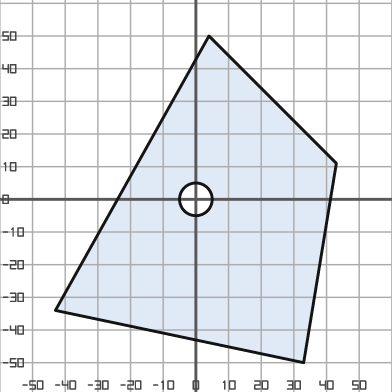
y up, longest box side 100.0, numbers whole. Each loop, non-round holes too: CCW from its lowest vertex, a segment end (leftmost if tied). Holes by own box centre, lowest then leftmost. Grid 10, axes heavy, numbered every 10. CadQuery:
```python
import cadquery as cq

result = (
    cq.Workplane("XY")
    .moveTo(33.0, -50.0)
    .lineTo(43.0, 11.0)
    .lineTo(4.0, 50.0)
    .lineTo(-43.0, -34.0)
    .close()
    .moveTo(0.0, 0.0)
    .circle(5.0)
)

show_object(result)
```